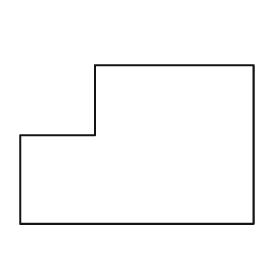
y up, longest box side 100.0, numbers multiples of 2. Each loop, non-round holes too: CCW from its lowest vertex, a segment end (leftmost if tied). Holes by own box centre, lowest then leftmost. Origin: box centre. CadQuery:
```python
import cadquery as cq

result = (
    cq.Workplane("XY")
    .moveTo(-50.0, -34.0)
    .lineTo(50.0, -34.0)
    .lineTo(50.0, 34.0)
    .lineTo(-18.0, 34.0)
    .lineTo(-18.0, 4.0)
    .lineTo(-50.0, 4.0)
    .close()
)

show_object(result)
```